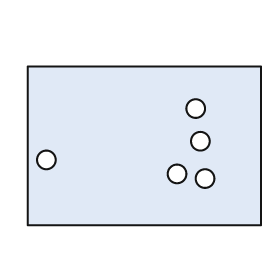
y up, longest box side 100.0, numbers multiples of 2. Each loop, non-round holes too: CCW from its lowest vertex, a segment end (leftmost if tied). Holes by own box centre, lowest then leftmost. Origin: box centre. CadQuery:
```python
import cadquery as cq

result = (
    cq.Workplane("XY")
    .moveTo(-50.0, -34.0)
    .lineTo(50.0, -34.0)
    .lineTo(50.0, 34.0)
    .lineTo(-50.0, 34.0)
    .close()
    .moveTo(26.0, -14.0)
    .circle(4.0)
    .moveTo(14.0, -12.0)
    .circle(4.0)
    .moveTo(-42.0, -6.0)
    .circle(4.0)
    .moveTo(24.0, 2.0)
    .circle(4.0)
    .moveTo(22.0, 16.0)
    .circle(4.0)
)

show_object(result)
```